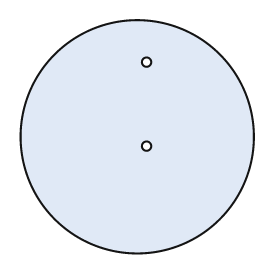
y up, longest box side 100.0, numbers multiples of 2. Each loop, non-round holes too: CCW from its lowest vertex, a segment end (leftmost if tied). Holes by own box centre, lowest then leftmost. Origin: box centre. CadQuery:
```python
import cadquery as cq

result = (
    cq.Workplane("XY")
    .moveTo(0.0, 0.0)
    .circle(50.0)
    .moveTo(4.0, -4.0)
    .circle(2.0)
    .moveTo(4.0, 32.0)
    .circle(2.0)
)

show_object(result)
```